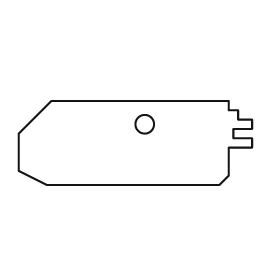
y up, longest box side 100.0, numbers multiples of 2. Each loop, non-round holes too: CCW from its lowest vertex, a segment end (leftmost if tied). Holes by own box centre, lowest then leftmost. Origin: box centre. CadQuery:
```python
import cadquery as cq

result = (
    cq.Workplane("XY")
    .moveTo(-38.0, -18.0)
    .lineTo(36.0, -18.0)
    .lineTo(40.0, -14.0)
    .lineTo(40.0, -2.0)
    .lineTo(50.0, -2.0)
    .lineTo(50.0, 2.0)
    .lineTo(42.0, 2.0)
    .lineTo(42.0, 6.0)
    .lineTo(50.0, 6.0)
    .lineTo(50.0, 10.0)
    .lineTo(44.0, 10.0)
    .lineTo(44.0, 14.0)
    .lineTo(40.0, 14.0)
    .lineTo(40.0, 18.0)
    .lineTo(-36.0, 18.0)
    .lineTo(-50.0, 4.0)
    .lineTo(-50.0, -12.0)
    .close()
    .moveTo(4.0, 8.0)
    .circle(4.0)
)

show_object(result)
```